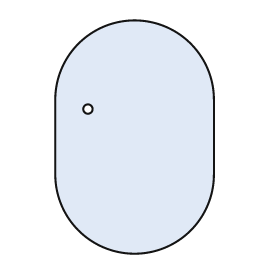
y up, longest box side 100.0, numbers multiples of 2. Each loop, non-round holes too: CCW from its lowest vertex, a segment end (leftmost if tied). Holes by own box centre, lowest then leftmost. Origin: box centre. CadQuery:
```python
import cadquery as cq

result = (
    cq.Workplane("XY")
    .moveTo(-34.0, -16.0)
    .threePointArc((0.0, -50.0), (34.0, -16.0))
    .lineTo(34.0, 16.0)
    .threePointArc((0.0, 50.0), (-34.0, 16.0))
    .close()
    .moveTo(-20.0, 12.0)
    .circle(2.0)
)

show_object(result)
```